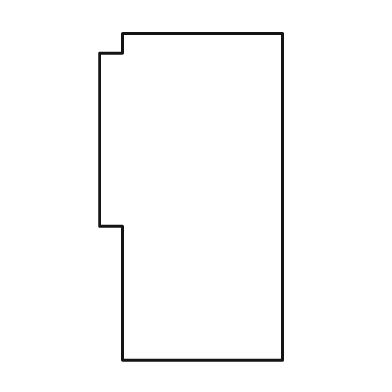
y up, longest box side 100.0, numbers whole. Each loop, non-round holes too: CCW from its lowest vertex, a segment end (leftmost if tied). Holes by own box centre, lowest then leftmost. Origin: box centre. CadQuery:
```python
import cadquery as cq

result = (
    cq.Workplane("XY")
    .moveTo(-21.0, -50.0)
    .lineTo(28.0, -50.0)
    .lineTo(28.0, 50.0)
    .lineTo(-21.0, 50.0)
    .lineTo(-21.0, 44.0)
    .lineTo(-28.0, 44.0)
    .lineTo(-28.0, -9.0)
    .lineTo(-21.0, -9.0)
    .close()
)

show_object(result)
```